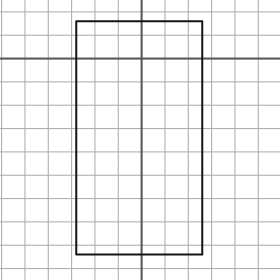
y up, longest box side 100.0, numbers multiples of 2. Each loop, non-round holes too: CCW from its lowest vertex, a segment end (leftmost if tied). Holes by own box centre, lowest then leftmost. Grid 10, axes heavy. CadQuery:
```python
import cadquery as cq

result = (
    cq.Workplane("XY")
    .moveTo(-28.0, -84.0)
    .lineTo(26.0, -84.0)
    .lineTo(26.0, 16.0)
    .lineTo(-28.0, 16.0)
    .close()
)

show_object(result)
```